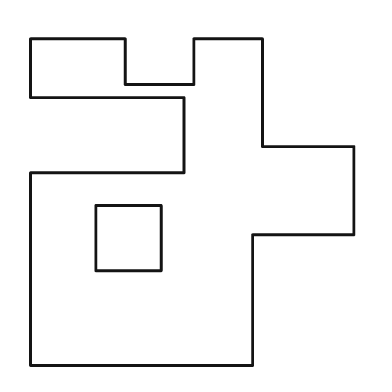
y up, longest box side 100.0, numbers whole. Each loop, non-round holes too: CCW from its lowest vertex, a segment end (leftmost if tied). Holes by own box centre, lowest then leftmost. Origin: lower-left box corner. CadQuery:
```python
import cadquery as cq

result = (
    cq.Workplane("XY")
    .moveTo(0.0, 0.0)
    .lineTo(68.0, 0.0)
    .lineTo(68.0, 40.0)
    .lineTo(99.0, 40.0)
    .lineTo(99.0, 67.0)
    .lineTo(71.0, 67.0)
    .lineTo(71.0, 100.0)
    .lineTo(50.0, 100.0)
    .lineTo(50.0, 86.0)
    .lineTo(29.0, 86.0)
    .lineTo(29.0, 100.0)
    .lineTo(0.0, 100.0)
    .lineTo(0.0, 82.0)
    .lineTo(47.0, 82.0)
    .lineTo(47.0, 59.0)
    .lineTo(0.0, 59.0)
    .close()
    .moveTo(20.0, 29.0)
    .lineTo(40.0, 29.0)
    .lineTo(40.0, 49.0)
    .lineTo(20.0, 49.0)
    .close()
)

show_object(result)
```